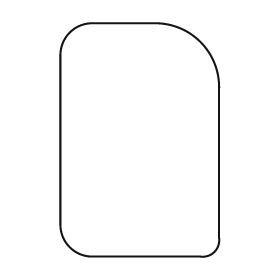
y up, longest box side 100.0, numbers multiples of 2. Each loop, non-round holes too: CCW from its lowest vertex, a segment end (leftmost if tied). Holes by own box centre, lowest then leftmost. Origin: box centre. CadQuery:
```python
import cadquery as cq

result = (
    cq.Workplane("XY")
    .moveTo(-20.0, -50.0)
    .lineTo(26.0, -50.0)
    .threePointArc((32.0, -48.0), (34.0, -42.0))
    .lineTo(34.0, 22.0)
    .threePointArc((26.0, 42.0), (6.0, 50.0))
    .lineTo(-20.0, 50.0)
    .threePointArc((-30.0, 46.0), (-34.0, 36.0))
    .lineTo(-34.0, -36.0)
    .threePointArc((-30.0, -46.0), (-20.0, -50.0))
    .close()
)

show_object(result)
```